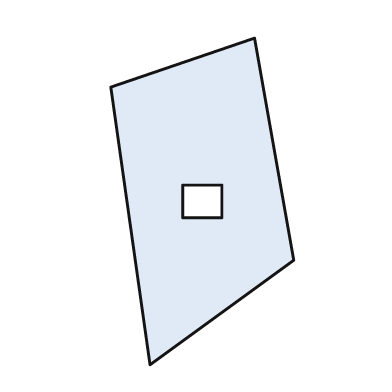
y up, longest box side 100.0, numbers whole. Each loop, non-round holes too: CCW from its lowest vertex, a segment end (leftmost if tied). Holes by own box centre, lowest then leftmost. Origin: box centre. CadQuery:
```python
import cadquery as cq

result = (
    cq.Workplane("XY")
    .moveTo(-16.0, -50.0)
    .lineTo(28.0, -18.0)
    .lineTo(16.0, 50.0)
    .lineTo(-28.0, 35.0)
    .close()
    .moveTo(-6.0, -5.0)
    .lineTo(6.0, -5.0)
    .lineTo(6.0, 5.0)
    .lineTo(-6.0, 5.0)
    .close()
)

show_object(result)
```